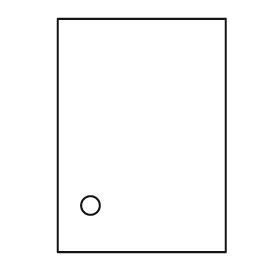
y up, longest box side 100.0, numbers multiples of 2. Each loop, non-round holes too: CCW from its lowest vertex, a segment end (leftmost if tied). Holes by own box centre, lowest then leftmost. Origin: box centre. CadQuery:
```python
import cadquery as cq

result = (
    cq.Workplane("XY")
    .moveTo(-36.0, -50.0)
    .lineTo(36.0, -50.0)
    .lineTo(36.0, 50.0)
    .lineTo(-36.0, 50.0)
    .close()
    .moveTo(-22.0, -30.0)
    .circle(4.0)
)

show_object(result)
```